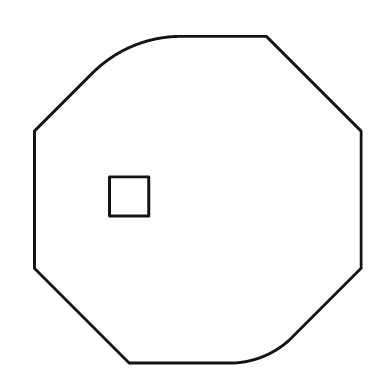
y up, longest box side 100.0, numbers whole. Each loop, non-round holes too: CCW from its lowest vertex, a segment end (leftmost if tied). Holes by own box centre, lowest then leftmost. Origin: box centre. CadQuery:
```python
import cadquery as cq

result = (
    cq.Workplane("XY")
    .moveTo(-21.0, -50.0)
    .lineTo(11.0, -50.0)
    .threePointArc((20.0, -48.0), (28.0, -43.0))
    .lineTo(50.0, -21.0)
    .lineTo(50.0, 21.0)
    .lineTo(21.0, 50.0)
    .lineTo(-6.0, 50.0)
    .threePointArc((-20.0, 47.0), (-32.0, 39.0))
    .lineTo(-50.0, 21.0)
    .lineTo(-50.0, -21.0)
    .close()
    .moveTo(-27.0, -5.0)
    .lineTo(-15.0, -5.0)
    .lineTo(-15.0, 7.0)
    .lineTo(-27.0, 7.0)
    .close()
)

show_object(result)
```